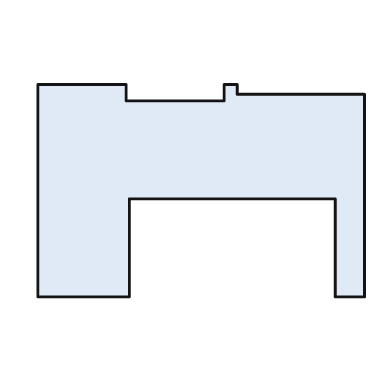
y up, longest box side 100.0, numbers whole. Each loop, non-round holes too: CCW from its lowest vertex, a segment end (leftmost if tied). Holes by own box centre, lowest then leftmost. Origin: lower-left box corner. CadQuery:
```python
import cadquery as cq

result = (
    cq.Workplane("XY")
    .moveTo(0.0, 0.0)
    .lineTo(28.0, 0.0)
    .lineTo(28.0, 30.0)
    .lineTo(91.0, 30.0)
    .lineTo(91.0, 0.0)
    .lineTo(100.0, 0.0)
    .lineTo(100.0, 62.0)
    .lineTo(61.0, 62.0)
    .lineTo(61.0, 65.0)
    .lineTo(57.0, 65.0)
    .lineTo(57.0, 60.0)
    .lineTo(27.0, 60.0)
    .lineTo(27.0, 65.0)
    .lineTo(0.0, 65.0)
    .close()
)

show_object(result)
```